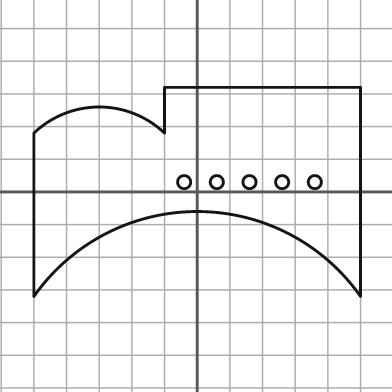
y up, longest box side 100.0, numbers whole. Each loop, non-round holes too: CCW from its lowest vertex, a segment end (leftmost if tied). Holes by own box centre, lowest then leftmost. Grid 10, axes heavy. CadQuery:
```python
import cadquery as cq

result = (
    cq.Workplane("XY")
    .moveTo(-50.0, -32.0)
    .threePointArc((0.0, -6.0), (50.0, -32.0))
    .lineTo(50.0, 32.0)
    .lineTo(-10.0, 32.0)
    .lineTo(-10.0, 18.0)
    .threePointArc((-30.0, 26.0), (-50.0, 18.0))
    .close()
    .moveTo(-4.0, 3.0)
    .circle(2.0)
    .moveTo(6.0, 3.0)
    .circle(2.0)
    .moveTo(16.0, 3.0)
    .circle(2.0)
    .moveTo(26.0, 3.0)
    .circle(2.0)
    .moveTo(36.0, 3.0)
    .circle(2.0)
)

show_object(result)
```